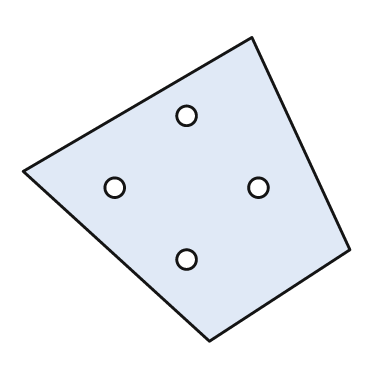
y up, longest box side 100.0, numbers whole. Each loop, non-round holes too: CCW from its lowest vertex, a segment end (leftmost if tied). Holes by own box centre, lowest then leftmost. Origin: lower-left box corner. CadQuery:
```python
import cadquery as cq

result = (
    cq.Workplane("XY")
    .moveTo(57.0, 0.0)
    .lineTo(100.0, 28.0)
    .lineTo(70.0, 93.0)
    .lineTo(0.0, 52.0)
    .close()
    .moveTo(50.0, 25.0)
    .circle(3.0)
    .moveTo(28.0, 47.0)
    .circle(3.0)
    .moveTo(72.0, 47.0)
    .circle(3.0)
    .moveTo(50.0, 69.0)
    .circle(3.0)
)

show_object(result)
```